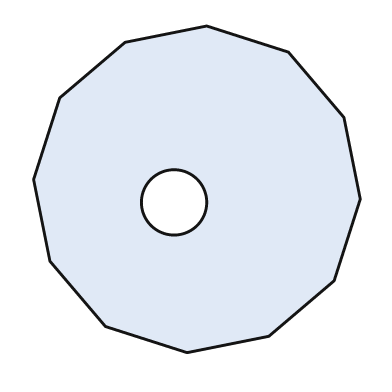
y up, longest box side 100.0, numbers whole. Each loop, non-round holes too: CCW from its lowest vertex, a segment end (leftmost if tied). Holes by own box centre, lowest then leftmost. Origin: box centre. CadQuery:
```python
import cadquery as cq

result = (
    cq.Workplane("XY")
    .moveTo(-3.0, -50.0)
    .lineTo(22.0, -45.0)
    .lineTo(42.0, -28.0)
    .lineTo(50.0, -3.0)
    .lineTo(45.0, 22.0)
    .lineTo(28.0, 42.0)
    .lineTo(3.0, 50.0)
    .lineTo(-22.0, 45.0)
    .lineTo(-42.0, 28.0)
    .lineTo(-50.0, 3.0)
    .lineTo(-45.0, -22.0)
    .lineTo(-28.0, -42.0)
    .close()
    .moveTo(-7.0, -4.0)
    .circle(10.0)
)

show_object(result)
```